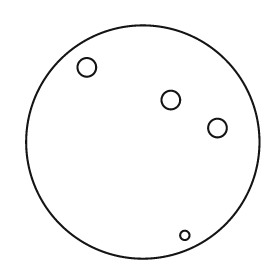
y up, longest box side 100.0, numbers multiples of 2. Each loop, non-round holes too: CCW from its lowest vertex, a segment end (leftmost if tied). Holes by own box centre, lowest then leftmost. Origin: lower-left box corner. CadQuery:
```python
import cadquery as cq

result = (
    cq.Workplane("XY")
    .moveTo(50.0, 50.0)
    .circle(50.0)
    .moveTo(68.0, 10.0)
    .circle(2.0)
    .moveTo(82.0, 56.0)
    .circle(4.0)
    .moveTo(62.0, 68.0)
    .circle(4.0)
    .moveTo(26.0, 82.0)
    .circle(4.0)
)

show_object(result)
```